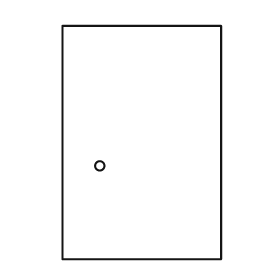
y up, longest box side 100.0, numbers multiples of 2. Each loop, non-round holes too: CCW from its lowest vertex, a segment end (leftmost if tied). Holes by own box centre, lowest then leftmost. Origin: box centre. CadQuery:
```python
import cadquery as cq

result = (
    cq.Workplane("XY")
    .moveTo(-34.0, -50.0)
    .lineTo(34.0, -50.0)
    .lineTo(34.0, 50.0)
    .lineTo(-34.0, 50.0)
    .close()
    .moveTo(-18.0, -10.0)
    .circle(2.0)
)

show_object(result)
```